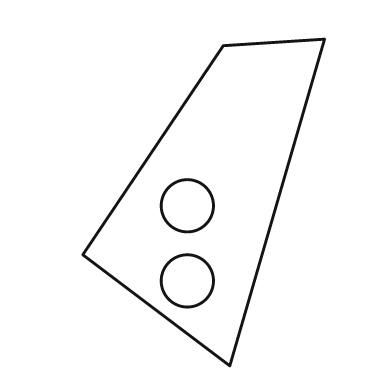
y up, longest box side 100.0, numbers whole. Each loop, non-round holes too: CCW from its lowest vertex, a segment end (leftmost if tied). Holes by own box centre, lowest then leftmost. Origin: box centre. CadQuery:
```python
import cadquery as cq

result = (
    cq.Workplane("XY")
    .moveTo(8.0, -50.0)
    .lineTo(37.0, 50.0)
    .lineTo(6.0, 48.0)
    .lineTo(-37.0, -16.0)
    .close()
    .moveTo(-5.0, -24.0)
    .circle(8.0)
    .moveTo(-5.0, -1.0)
    .circle(8.0)
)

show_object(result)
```